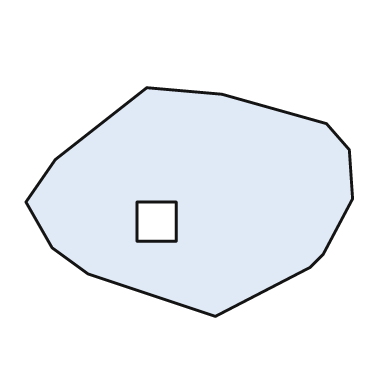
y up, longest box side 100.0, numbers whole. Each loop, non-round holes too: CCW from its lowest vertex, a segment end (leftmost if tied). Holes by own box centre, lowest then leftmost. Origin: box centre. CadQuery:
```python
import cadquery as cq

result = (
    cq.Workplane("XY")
    .moveTo(8.0, -35.0)
    .lineTo(37.0, -20.0)
    .lineTo(41.0, -16.0)
    .lineTo(50.0, 1.0)
    .lineTo(49.0, 16.0)
    .lineTo(42.0, 24.0)
    .lineTo(10.0, 33.0)
    .lineTo(-13.0, 35.0)
    .lineTo(-41.0, 13.0)
    .lineTo(-50.0, 0.0)
    .lineTo(-42.0, -14.0)
    .lineTo(-31.0, -22.0)
    .close()
    .moveTo(-16.0, -12.0)
    .lineTo(-4.0, -12.0)
    .lineTo(-4.0, 0.0)
    .lineTo(-16.0, 0.0)
    .close()
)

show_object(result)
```